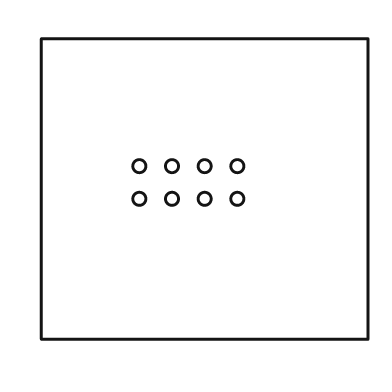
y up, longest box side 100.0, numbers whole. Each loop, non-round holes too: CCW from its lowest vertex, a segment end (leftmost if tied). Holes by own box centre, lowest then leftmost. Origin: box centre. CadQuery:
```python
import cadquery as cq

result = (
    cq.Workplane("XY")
    .moveTo(-50.0, -46.0)
    .lineTo(50.0, -46.0)
    .lineTo(50.0, 46.0)
    .lineTo(-50.0, 46.0)
    .close()
    .moveTo(-20.0, -3.0)
    .circle(2.0)
    .moveTo(-10.0, -3.0)
    .circle(2.0)
    .moveTo(0.0, -3.0)
    .circle(2.0)
    .moveTo(10.0, -3.0)
    .circle(2.0)
    .moveTo(-20.0, 7.0)
    .circle(2.0)
    .moveTo(-10.0, 7.0)
    .circle(2.0)
    .moveTo(0.0, 7.0)
    .circle(2.0)
    .moveTo(10.0, 7.0)
    .circle(2.0)
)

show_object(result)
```